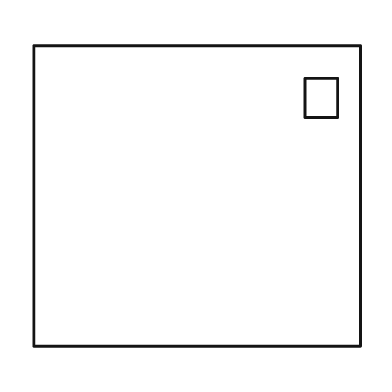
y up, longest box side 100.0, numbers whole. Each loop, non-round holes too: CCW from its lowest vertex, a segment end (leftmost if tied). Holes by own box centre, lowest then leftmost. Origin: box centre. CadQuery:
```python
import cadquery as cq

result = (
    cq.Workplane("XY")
    .moveTo(-50.0, -46.0)
    .lineTo(50.0, -46.0)
    .lineTo(50.0, 46.0)
    .lineTo(-50.0, 46.0)
    .close()
    .moveTo(33.0, 24.0)
    .lineTo(43.0, 24.0)
    .lineTo(43.0, 36.0)
    .lineTo(33.0, 36.0)
    .close()
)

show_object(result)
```